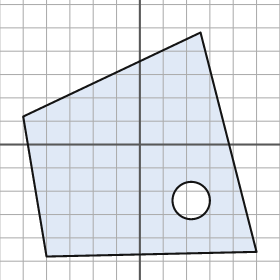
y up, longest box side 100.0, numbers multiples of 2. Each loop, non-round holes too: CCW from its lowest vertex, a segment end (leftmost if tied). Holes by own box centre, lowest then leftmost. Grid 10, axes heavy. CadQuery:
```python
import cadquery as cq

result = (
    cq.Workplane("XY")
    .moveTo(-40.0, -48.0)
    .lineTo(50.0, -46.0)
    .lineTo(26.0, 48.0)
    .lineTo(-50.0, 12.0)
    .close()
    .moveTo(22.0, -24.0)
    .circle(8.0)
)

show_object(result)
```